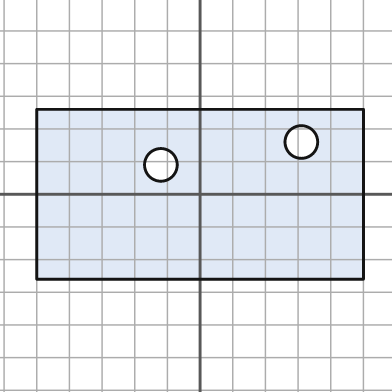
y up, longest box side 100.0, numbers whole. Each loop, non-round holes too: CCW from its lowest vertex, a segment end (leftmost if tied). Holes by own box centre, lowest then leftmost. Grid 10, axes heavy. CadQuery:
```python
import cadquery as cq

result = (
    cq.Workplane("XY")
    .moveTo(-50.0, -26.0)
    .lineTo(50.0, -26.0)
    .lineTo(50.0, 26.0)
    .lineTo(-50.0, 26.0)
    .close()
    .moveTo(-12.0, 9.0)
    .circle(5.0)
    .moveTo(31.0, 16.0)
    .circle(5.0)
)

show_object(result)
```